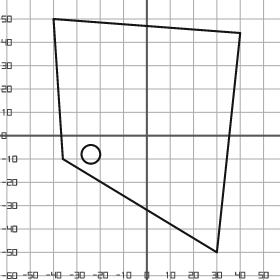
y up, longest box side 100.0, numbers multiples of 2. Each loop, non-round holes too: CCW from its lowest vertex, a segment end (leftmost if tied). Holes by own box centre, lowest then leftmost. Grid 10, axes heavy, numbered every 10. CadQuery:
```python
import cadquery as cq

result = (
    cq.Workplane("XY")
    .moveTo(30.0, -50.0)
    .lineTo(40.0, 44.0)
    .lineTo(-40.0, 50.0)
    .lineTo(-36.0, -10.0)
    .close()
    .moveTo(-24.0, -8.0)
    .circle(4.0)
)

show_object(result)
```